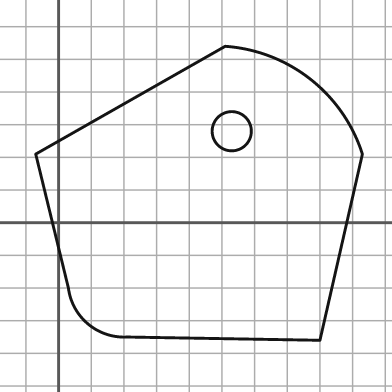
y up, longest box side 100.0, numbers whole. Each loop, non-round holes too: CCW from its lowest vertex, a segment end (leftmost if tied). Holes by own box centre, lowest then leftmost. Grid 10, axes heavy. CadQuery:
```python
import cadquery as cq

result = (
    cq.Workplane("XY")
    .moveTo(80.0, -36.0)
    .lineTo(93.0, 21.0)
    .threePointArc((77.0, 44.0), (51.0, 54.0))
    .lineTo(-7.0, 21.0)
    .lineTo(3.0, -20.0)
    .threePointArc((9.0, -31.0), (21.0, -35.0))
    .close()
    .moveTo(53.0, 28.0)
    .circle(6.0)
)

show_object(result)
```